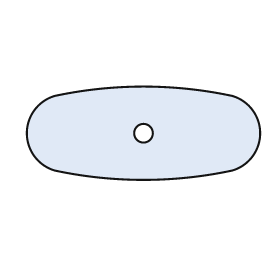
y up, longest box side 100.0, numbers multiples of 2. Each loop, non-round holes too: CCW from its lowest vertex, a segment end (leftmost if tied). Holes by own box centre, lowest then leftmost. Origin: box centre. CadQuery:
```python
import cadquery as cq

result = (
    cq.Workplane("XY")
    .moveTo(-38.0, -16.0)
    .threePointArc((0.0, -20.0), (38.0, -16.0))
    .threePointArc((50.0, 0.0), (38.0, 16.0))
    .threePointArc((0.0, 20.0), (-38.0, 16.0))
    .threePointArc((-50.0, 0.0), (-38.0, -16.0))
    .close()
    .moveTo(0.0, 0.0)
    .circle(4.0)
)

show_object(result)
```